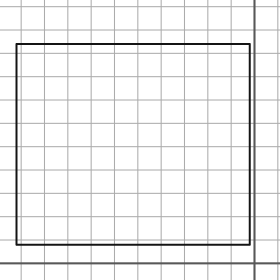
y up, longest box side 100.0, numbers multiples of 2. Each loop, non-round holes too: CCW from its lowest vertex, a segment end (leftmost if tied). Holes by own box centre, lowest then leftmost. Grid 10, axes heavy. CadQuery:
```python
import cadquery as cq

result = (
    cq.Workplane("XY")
    .moveTo(-102.0, 8.0)
    .lineTo(-2.0, 8.0)
    .lineTo(-2.0, 94.0)
    .lineTo(-102.0, 94.0)
    .close()
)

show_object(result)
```